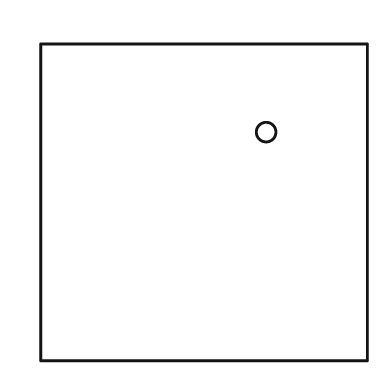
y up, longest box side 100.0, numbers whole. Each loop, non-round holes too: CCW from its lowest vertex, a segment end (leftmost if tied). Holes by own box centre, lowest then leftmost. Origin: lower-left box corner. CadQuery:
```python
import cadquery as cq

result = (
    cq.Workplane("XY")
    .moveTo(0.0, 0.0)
    .lineTo(100.0, 0.0)
    .lineTo(100.0, 97.0)
    .lineTo(0.0, 97.0)
    .close()
    .moveTo(69.0, 70.0)
    .circle(3.0)
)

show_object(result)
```